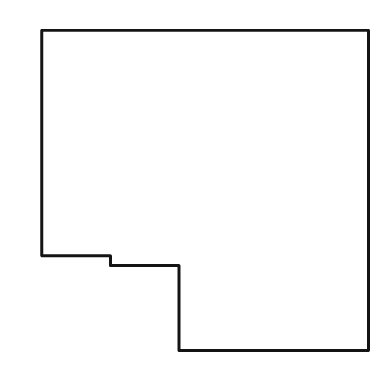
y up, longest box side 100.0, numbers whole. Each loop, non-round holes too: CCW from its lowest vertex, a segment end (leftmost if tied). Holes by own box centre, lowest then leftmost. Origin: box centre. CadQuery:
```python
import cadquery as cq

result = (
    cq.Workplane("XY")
    .moveTo(-8.0, -49.0)
    .lineTo(50.0, -49.0)
    .lineTo(50.0, 49.0)
    .lineTo(-50.0, 49.0)
    .lineTo(-50.0, -20.0)
    .lineTo(-29.0, -20.0)
    .lineTo(-29.0, -23.0)
    .lineTo(-8.0, -23.0)
    .close()
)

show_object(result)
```